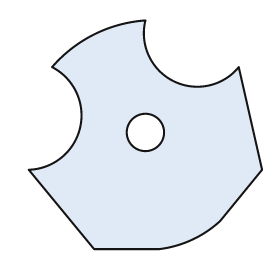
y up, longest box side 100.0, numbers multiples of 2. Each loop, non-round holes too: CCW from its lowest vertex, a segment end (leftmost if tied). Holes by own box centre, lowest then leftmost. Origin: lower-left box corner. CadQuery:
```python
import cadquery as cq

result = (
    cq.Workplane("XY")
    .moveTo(28.0, 0.0)
    .lineTo(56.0, 0.0)
    .threePointArc((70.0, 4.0), (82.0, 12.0))
    .lineTo(100.0, 34.0)
    .lineTo(90.0, 78.0)
    .threePointArc((62.0, 72.0), (50.0, 98.0))
    .threePointArc((28.0, 92.0), (10.0, 78.0))
    .threePointArc((22.0, 52.0), (0.0, 34.0))
    .close()
    .moveTo(50.0, 50.0)
    .circle(8.0)
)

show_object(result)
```